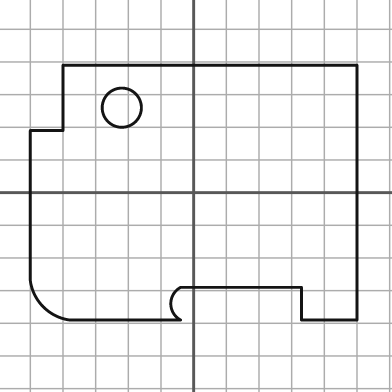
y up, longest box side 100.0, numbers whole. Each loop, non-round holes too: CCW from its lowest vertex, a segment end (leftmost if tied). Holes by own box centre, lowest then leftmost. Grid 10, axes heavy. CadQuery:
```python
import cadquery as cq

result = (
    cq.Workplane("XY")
    .moveTo(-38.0, -39.0)
    .lineTo(-4.0, -39.0)
    .threePointArc((-7.0, -34.0), (-4.0, -29.0))
    .lineTo(33.0, -29.0)
    .lineTo(33.0, -39.0)
    .lineTo(50.0, -39.0)
    .lineTo(50.0, 39.0)
    .lineTo(-40.0, 39.0)
    .lineTo(-40.0, 19.0)
    .lineTo(-50.0, 19.0)
    .lineTo(-50.0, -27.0)
    .threePointArc((-46.0, -35.0), (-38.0, -39.0))
    .close()
    .moveTo(-22.0, 26.0)
    .circle(6.0)
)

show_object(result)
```